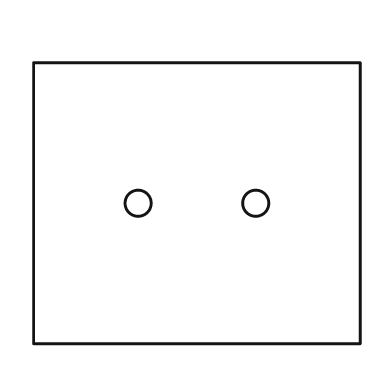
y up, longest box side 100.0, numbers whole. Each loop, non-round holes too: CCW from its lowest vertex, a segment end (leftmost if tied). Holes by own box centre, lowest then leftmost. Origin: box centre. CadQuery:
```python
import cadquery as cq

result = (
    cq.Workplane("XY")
    .moveTo(-50.0, -43.0)
    .lineTo(50.0, -43.0)
    .lineTo(50.0, 43.0)
    .lineTo(-50.0, 43.0)
    .close()
    .moveTo(-18.0, 0.0)
    .circle(4.0)
    .moveTo(18.0, 0.0)
    .circle(4.0)
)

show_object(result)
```